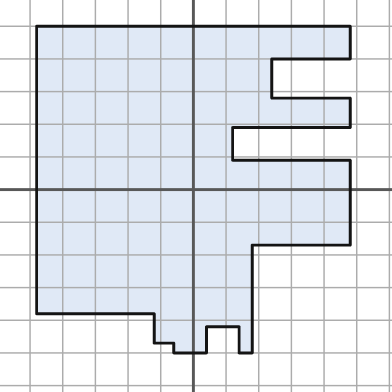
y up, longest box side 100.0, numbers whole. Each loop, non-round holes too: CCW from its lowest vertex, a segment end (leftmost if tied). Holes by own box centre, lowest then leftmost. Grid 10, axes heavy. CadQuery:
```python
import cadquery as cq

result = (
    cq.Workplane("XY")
    .moveTo(-6.0, -50.0)
    .lineTo(4.0, -50.0)
    .lineTo(4.0, -42.0)
    .lineTo(14.0, -42.0)
    .lineTo(14.0, -50.0)
    .lineTo(18.0, -50.0)
    .lineTo(18.0, -17.0)
    .lineTo(48.0, -17.0)
    .lineTo(48.0, 9.0)
    .lineTo(12.0, 9.0)
    .lineTo(12.0, 19.0)
    .lineTo(48.0, 19.0)
    .lineTo(48.0, 28.0)
    .lineTo(24.0, 28.0)
    .lineTo(24.0, 40.0)
    .lineTo(48.0, 40.0)
    .lineTo(48.0, 50.0)
    .lineTo(-48.0, 50.0)
    .lineTo(-48.0, -38.0)
    .lineTo(-12.0, -38.0)
    .lineTo(-12.0, -47.0)
    .lineTo(-6.0, -47.0)
    .close()
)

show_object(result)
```